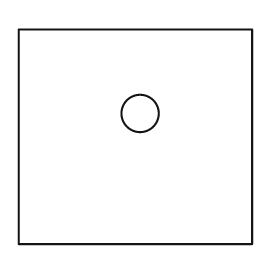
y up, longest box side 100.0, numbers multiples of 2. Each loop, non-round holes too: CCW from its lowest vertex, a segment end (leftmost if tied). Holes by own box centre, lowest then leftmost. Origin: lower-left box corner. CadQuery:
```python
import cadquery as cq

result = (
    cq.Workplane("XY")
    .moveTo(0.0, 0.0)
    .lineTo(100.0, 0.0)
    .lineTo(100.0, 92.0)
    .lineTo(0.0, 92.0)
    .close()
    .moveTo(52.0, 56.0)
    .circle(8.0)
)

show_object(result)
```